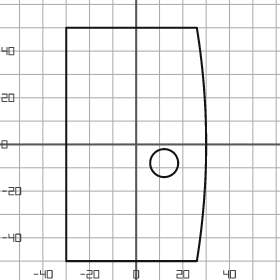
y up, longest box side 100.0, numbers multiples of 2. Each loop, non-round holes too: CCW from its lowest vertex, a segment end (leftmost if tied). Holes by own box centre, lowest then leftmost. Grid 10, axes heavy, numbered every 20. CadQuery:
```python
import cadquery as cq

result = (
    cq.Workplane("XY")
    .moveTo(-30.0, -50.0)
    .lineTo(26.0, -50.0)
    .threePointArc((30.0, 0.0), (26.0, 50.0))
    .lineTo(-30.0, 50.0)
    .close()
    .moveTo(12.0, -8.0)
    .circle(6.0)
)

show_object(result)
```